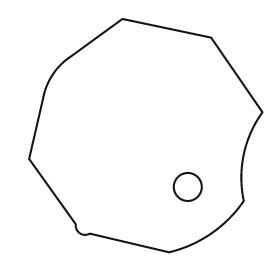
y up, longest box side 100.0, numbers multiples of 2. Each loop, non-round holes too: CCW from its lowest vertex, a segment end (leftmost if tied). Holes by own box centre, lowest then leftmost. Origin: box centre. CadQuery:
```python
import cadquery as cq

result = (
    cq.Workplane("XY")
    .moveTo(10.0, -50.0)
    .threePointArc((28.0, -42.0), (42.0, -28.0))
    .threePointArc((42.0, -8.0), (50.0, 10.0))
    .lineTo(28.0, 42.0)
    .lineTo(-10.0, 50.0)
    .lineTo(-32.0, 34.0)
    .threePointArc((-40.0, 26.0), (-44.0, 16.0))
    .lineTo(-50.0, -10.0)
    .lineTo(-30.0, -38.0)
    .threePointArc((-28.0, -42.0), (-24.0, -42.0))
    .close()
    .moveTo(18.0, -22.0)
    .circle(6.0)
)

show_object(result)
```